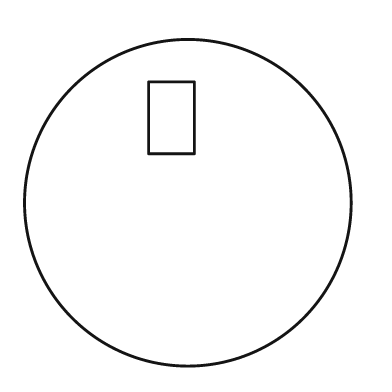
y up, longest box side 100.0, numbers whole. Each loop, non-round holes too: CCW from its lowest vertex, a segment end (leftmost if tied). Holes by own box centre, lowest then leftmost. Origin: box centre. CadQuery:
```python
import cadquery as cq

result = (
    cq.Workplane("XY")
    .moveTo(0.0, 0.0)
    .circle(50.0)
    .moveTo(-12.0, 15.0)
    .lineTo(2.0, 15.0)
    .lineTo(2.0, 37.0)
    .lineTo(-12.0, 37.0)
    .close()
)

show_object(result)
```